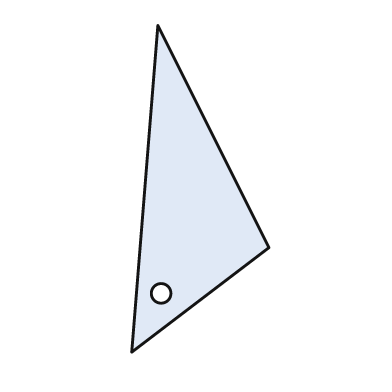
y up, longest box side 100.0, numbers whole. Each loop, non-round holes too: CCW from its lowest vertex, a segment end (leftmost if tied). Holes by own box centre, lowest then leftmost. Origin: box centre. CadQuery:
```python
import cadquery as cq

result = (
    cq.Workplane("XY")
    .moveTo(-21.0, -50.0)
    .lineTo(21.0, -18.0)
    .lineTo(-13.0, 50.0)
    .close()
    .moveTo(-12.0, -32.0)
    .circle(3.0)
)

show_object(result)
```